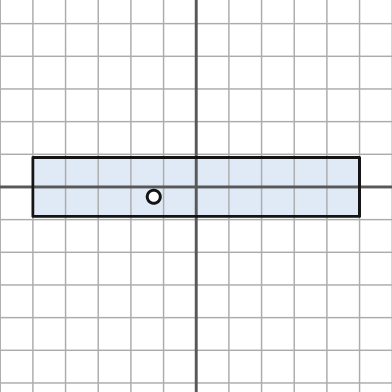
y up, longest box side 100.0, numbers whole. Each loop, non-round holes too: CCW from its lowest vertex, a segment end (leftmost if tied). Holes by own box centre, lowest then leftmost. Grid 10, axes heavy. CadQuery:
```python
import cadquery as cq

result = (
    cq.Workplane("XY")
    .moveTo(-50.0, -9.0)
    .lineTo(50.0, -9.0)
    .lineTo(50.0, 9.0)
    .lineTo(-50.0, 9.0)
    .close()
    .moveTo(-13.0, -3.0)
    .circle(2.0)
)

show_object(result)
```